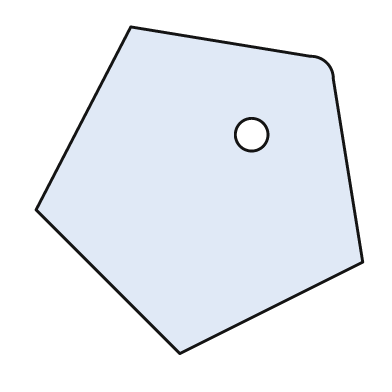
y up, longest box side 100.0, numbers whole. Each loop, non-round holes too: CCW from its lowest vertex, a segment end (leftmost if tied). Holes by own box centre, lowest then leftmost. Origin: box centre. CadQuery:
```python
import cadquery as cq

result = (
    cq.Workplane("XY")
    .moveTo(-6.0, -50.0)
    .lineTo(50.0, -22.0)
    .lineTo(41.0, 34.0)
    .threePointArc((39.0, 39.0), (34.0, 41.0))
    .lineTo(-21.0, 50.0)
    .lineTo(-50.0, -6.0)
    .close()
    .moveTo(16.0, 17.0)
    .circle(5.0)
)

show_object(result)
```